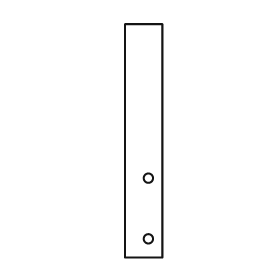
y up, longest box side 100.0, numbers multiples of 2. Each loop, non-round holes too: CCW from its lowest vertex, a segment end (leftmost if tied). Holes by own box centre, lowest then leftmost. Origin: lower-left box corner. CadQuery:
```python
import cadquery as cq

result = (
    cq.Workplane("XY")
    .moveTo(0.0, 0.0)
    .lineTo(16.0, 0.0)
    .lineTo(16.0, 100.0)
    .lineTo(0.0, 100.0)
    .close()
    .moveTo(10.0, 8.0)
    .circle(2.0)
    .moveTo(10.0, 34.0)
    .circle(2.0)
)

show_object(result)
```